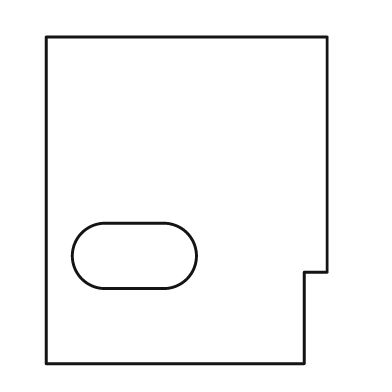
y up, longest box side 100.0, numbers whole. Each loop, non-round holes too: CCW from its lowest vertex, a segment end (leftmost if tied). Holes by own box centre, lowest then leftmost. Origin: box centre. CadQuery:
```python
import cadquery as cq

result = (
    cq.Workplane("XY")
    .moveTo(-43.0, -50.0)
    .lineTo(36.0, -50.0)
    .lineTo(36.0, -22.0)
    .lineTo(43.0, -22.0)
    .lineTo(43.0, 50.0)
    .lineTo(-43.0, 50.0)
    .close()
    .moveTo(-25.0, -27.0)
    .lineTo(-7.0, -27.0)
    .threePointArc((3.0, -17.0), (-7.0, -7.0))
    .lineTo(-25.0, -7.0)
    .threePointArc((-35.0, -17.0), (-25.0, -27.0))
    .close()
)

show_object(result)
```